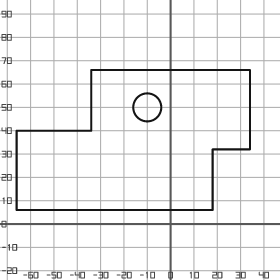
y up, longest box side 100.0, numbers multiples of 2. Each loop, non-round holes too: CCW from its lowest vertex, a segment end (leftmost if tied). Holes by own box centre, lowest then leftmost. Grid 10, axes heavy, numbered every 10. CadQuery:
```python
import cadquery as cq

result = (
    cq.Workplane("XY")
    .moveTo(-66.0, 6.0)
    .lineTo(18.0, 6.0)
    .lineTo(18.0, 32.0)
    .lineTo(34.0, 32.0)
    .lineTo(34.0, 66.0)
    .lineTo(-34.0, 66.0)
    .lineTo(-34.0, 40.0)
    .lineTo(-66.0, 40.0)
    .close()
    .moveTo(-10.0, 50.0)
    .circle(6.0)
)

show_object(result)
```